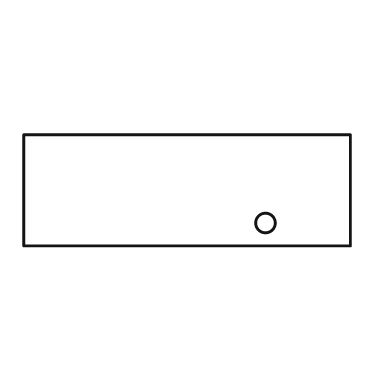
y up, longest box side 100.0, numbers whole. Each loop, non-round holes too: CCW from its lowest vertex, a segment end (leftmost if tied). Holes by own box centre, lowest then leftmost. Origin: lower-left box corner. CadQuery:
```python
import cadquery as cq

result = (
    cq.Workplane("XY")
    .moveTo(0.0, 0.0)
    .lineTo(100.0, 0.0)
    .lineTo(100.0, 34.0)
    .lineTo(0.0, 34.0)
    .close()
    .moveTo(74.0, 7.0)
    .circle(3.0)
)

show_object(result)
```